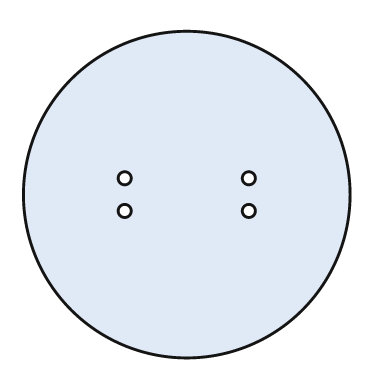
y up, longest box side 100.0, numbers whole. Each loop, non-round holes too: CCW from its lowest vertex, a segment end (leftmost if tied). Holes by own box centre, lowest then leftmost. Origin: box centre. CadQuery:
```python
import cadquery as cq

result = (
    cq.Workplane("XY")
    .moveTo(0.0, 0.0)
    .circle(50.0)
    .moveTo(-19.0, -5.0)
    .circle(2.0)
    .moveTo(19.0, -5.0)
    .circle(2.0)
    .moveTo(-19.0, 5.0)
    .circle(2.0)
    .moveTo(19.0, 5.0)
    .circle(2.0)
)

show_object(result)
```